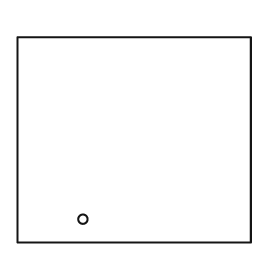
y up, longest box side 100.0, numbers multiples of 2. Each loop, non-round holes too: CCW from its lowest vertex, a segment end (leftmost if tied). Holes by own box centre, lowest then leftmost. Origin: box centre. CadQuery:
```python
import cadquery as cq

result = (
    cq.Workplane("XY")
    .moveTo(-50.0, -44.0)
    .lineTo(50.0, -44.0)
    .lineTo(50.0, 44.0)
    .lineTo(-50.0, 44.0)
    .close()
    .moveTo(-22.0, -34.0)
    .circle(2.0)
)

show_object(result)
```